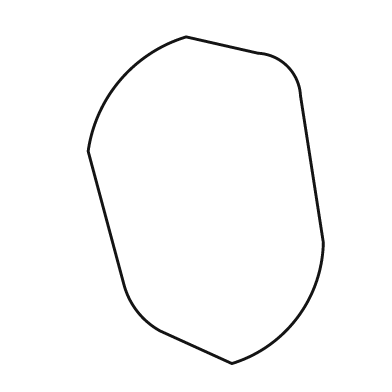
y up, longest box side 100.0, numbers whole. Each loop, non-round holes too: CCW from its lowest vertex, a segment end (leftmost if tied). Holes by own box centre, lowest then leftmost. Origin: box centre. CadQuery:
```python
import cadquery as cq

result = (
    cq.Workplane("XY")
    .moveTo(8.0, -50.0)
    .threePointArc((28.0, -36.0), (36.0, -13.0))
    .lineTo(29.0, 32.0)
    .threePointArc((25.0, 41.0), (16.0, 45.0))
    .lineTo(-6.0, 50.0)
    .threePointArc((-26.0, 37.0), (-36.0, 15.0))
    .lineTo(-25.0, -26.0)
    .threePointArc((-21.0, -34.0), (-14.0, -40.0))
    .close()
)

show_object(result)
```